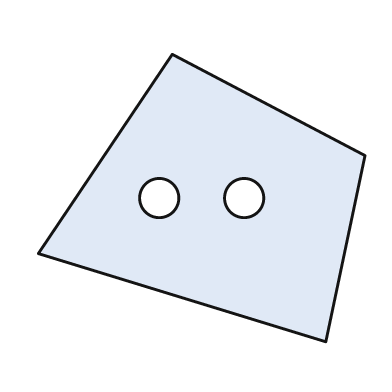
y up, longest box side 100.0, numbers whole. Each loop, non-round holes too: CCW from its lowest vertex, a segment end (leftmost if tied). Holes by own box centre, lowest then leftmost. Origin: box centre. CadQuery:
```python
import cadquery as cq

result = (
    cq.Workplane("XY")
    .moveTo(38.0, -44.0)
    .lineTo(50.0, 13.0)
    .lineTo(-9.0, 44.0)
    .lineTo(-50.0, -17.0)
    .close()
    .moveTo(-13.0, 0.0)
    .circle(6.0)
    .moveTo(13.0, 0.0)
    .circle(6.0)
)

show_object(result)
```